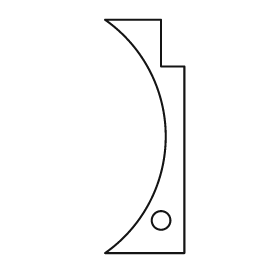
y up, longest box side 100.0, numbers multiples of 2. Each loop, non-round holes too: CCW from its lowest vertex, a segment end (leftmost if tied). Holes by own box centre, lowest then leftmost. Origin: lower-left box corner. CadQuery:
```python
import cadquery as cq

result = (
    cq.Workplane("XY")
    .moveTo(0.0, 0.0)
    .lineTo(34.0, 0.0)
    .lineTo(34.0, 80.0)
    .lineTo(24.0, 80.0)
    .lineTo(24.0, 100.0)
    .lineTo(0.0, 100.0)
    .threePointArc((26.0, 50.0), (0.0, 0.0))
    .close()
    .moveTo(24.0, 14.0)
    .circle(4.0)
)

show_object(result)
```